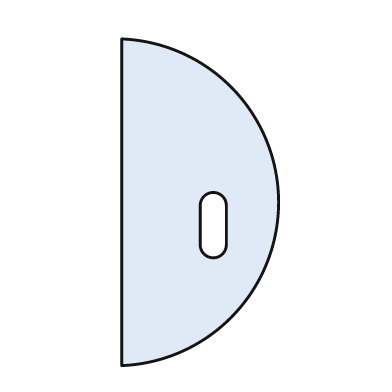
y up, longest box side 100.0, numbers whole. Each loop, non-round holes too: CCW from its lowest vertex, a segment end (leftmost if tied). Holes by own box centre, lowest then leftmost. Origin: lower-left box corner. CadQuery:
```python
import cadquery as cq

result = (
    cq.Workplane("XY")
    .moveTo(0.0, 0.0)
    .threePointArc((48.0, 50.0), (0.0, 100.0))
    .close()
    .moveTo(24.0, 37.0)
    .threePointArc((28.0, 33.0), (32.0, 37.0))
    .lineTo(32.0, 49.0)
    .threePointArc((28.0, 53.0), (24.0, 49.0))
    .close()
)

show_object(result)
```